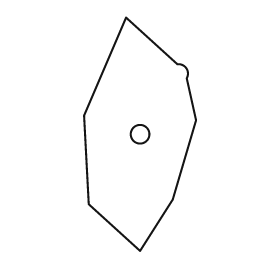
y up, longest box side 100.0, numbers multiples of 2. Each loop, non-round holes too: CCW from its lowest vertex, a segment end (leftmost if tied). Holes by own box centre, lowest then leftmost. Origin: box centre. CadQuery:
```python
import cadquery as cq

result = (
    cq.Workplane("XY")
    .moveTo(0.0, -50.0)
    .lineTo(14.0, -28.0)
    .lineTo(24.0, 6.0)
    .lineTo(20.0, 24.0)
    .threePointArc((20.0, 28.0), (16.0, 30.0))
    .lineTo(-6.0, 50.0)
    .lineTo(-24.0, 8.0)
    .lineTo(-22.0, -30.0)
    .close()
    .moveTo(0.0, 0.0)
    .circle(4.0)
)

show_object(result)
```